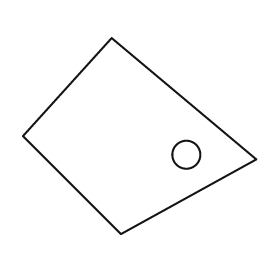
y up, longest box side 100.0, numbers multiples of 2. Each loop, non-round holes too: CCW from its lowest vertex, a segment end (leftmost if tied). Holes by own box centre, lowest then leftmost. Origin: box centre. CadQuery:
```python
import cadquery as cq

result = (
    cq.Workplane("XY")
    .moveTo(-8.0, -42.0)
    .lineTo(50.0, -10.0)
    .lineTo(-12.0, 42.0)
    .lineTo(-50.0, 0.0)
    .close()
    .moveTo(20.0, -8.0)
    .circle(6.0)
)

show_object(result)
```